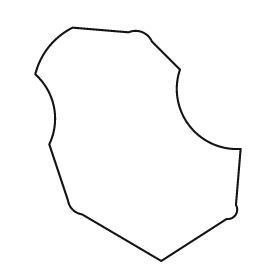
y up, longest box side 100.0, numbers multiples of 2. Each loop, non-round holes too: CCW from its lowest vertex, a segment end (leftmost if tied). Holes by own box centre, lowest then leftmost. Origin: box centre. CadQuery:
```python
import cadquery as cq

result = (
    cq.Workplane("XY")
    .moveTo(10.0, -50.0)
    .lineTo(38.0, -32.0)
    .threePointArc((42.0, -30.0), (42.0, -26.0))
    .lineTo(44.0, -2.0)
    .threePointArc((22.0, 8.0), (18.0, 32.0))
    .lineTo(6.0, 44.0)
    .threePointArc((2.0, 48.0), (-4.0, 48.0))
    .lineTo(-28.0, 50.0)
    .threePointArc((-38.0, 42.0), (-44.0, 30.0))
    .threePointArc((-36.0, 16.0), (-38.0, 0.0))
    .lineTo(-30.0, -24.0)
    .threePointArc((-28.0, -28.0), (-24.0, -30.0))
    .close()
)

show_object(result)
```